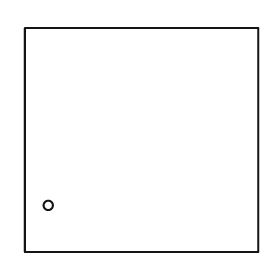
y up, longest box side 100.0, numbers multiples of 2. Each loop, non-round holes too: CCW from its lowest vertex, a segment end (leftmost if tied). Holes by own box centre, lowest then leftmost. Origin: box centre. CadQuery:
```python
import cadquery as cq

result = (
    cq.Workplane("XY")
    .moveTo(-50.0, -48.0)
    .lineTo(50.0, -48.0)
    .lineTo(50.0, 48.0)
    .lineTo(-50.0, 48.0)
    .close()
    .moveTo(-40.0, -28.0)
    .circle(2.0)
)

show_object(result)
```